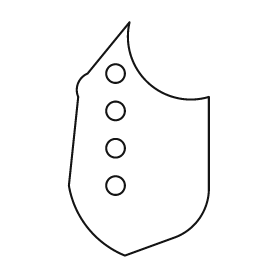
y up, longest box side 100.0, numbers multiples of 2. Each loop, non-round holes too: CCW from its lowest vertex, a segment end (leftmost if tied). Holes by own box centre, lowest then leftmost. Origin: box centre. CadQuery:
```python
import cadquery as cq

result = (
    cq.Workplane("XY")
    .moveTo(-6.0, -50.0)
    .lineTo(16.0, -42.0)
    .threePointArc((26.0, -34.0), (30.0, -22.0))
    .lineTo(30.0, 18.0)
    .threePointArc((4.0, 24.0), (-4.0, 50.0))
    .lineTo(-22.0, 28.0)
    .threePointArc((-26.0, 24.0), (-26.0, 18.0))
    .lineTo(-30.0, -20.0)
    .threePointArc((-22.0, -38.0), (-6.0, -50.0))
    .close()
    .moveTo(-10.0, -20.0)
    .circle(4.0)
    .moveTo(-10.0, -4.0)
    .circle(4.0)
    .moveTo(-10.0, 12.0)
    .circle(4.0)
    .moveTo(-10.0, 28.0)
    .circle(4.0)
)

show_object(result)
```